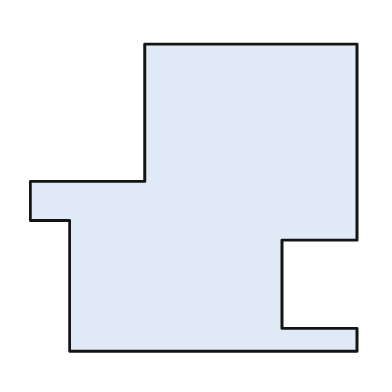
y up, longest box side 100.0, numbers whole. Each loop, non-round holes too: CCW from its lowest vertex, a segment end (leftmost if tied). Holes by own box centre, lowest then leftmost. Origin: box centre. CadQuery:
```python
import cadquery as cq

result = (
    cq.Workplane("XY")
    .moveTo(-38.0, -47.0)
    .lineTo(50.0, -47.0)
    .lineTo(50.0, -40.0)
    .lineTo(27.0, -40.0)
    .lineTo(27.0, -13.0)
    .lineTo(50.0, -13.0)
    .lineTo(50.0, 47.0)
    .lineTo(-15.0, 47.0)
    .lineTo(-15.0, 5.0)
    .lineTo(-50.0, 5.0)
    .lineTo(-50.0, -7.0)
    .lineTo(-38.0, -7.0)
    .close()
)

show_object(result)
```